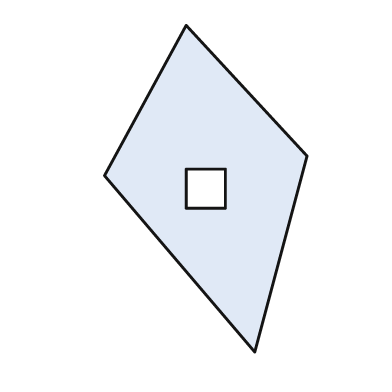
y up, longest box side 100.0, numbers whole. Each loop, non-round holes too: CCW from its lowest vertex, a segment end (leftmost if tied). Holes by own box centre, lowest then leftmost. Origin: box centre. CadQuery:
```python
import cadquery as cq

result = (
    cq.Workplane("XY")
    .moveTo(15.0, -50.0)
    .lineTo(31.0, 10.0)
    .lineTo(-6.0, 50.0)
    .lineTo(-31.0, 4.0)
    .close()
    .moveTo(-6.0, -6.0)
    .lineTo(6.0, -6.0)
    .lineTo(6.0, 6.0)
    .lineTo(-6.0, 6.0)
    .close()
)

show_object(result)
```